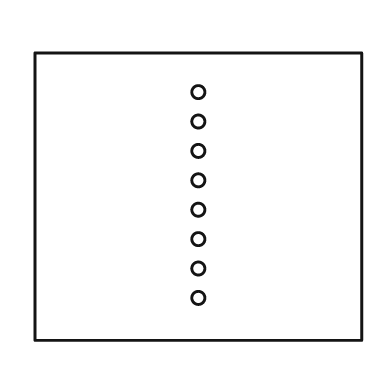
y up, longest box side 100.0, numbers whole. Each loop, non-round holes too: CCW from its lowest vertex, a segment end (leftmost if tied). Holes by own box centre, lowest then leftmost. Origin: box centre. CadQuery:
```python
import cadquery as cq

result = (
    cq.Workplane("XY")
    .moveTo(-50.0, -44.0)
    .lineTo(50.0, -44.0)
    .lineTo(50.0, 44.0)
    .lineTo(-50.0, 44.0)
    .close()
    .moveTo(0.0, -31.0)
    .circle(2.0)
    .moveTo(0.0, -22.0)
    .circle(2.0)
    .moveTo(0.0, -13.0)
    .circle(2.0)
    .moveTo(0.0, -4.0)
    .circle(2.0)
    .moveTo(0.0, 5.0)
    .circle(2.0)
    .moveTo(0.0, 14.0)
    .circle(2.0)
    .moveTo(0.0, 23.0)
    .circle(2.0)
    .moveTo(0.0, 32.0)
    .circle(2.0)
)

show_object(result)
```